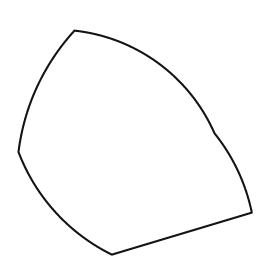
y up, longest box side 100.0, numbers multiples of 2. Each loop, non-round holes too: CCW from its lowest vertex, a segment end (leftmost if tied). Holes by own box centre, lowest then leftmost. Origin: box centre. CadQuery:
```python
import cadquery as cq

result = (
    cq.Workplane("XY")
    .moveTo(-10.0, -48.0)
    .lineTo(50.0, -30.0)
    .threePointArc((44.0, -12.0), (34.0, 4.0))
    .threePointArc((10.0, 34.0), (-26.0, 48.0))
    .threePointArc((-42.0, 24.0), (-50.0, -4.0))
    .threePointArc((-34.0, -30.0), (-10.0, -48.0))
    .close()
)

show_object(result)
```